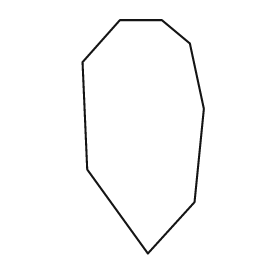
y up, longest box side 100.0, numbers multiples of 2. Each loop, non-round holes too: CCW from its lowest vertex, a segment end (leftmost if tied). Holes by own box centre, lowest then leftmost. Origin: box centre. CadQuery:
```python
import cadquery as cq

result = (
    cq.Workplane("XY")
    .moveTo(2.0, -50.0)
    .lineTo(22.0, -28.0)
    .lineTo(26.0, 12.0)
    .lineTo(20.0, 40.0)
    .lineTo(8.0, 50.0)
    .lineTo(-10.0, 50.0)
    .lineTo(-26.0, 32.0)
    .lineTo(-24.0, -14.0)
    .close()
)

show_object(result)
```